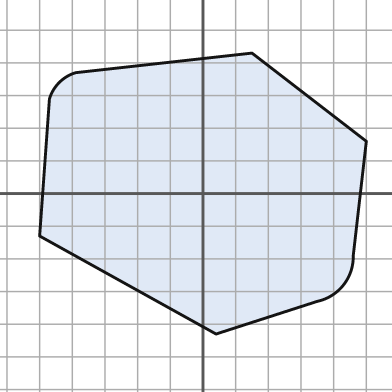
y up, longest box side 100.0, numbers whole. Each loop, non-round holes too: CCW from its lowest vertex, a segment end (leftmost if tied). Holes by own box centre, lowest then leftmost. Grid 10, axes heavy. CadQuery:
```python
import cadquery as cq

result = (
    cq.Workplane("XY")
    .moveTo(4.0, -43.0)
    .lineTo(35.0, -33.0)
    .threePointArc((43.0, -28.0), (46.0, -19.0))
    .lineTo(50.0, 16.0)
    .lineTo(15.0, 43.0)
    .lineTo(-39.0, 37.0)
    .threePointArc((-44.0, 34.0), (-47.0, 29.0))
    .lineTo(-50.0, -13.0)
    .close()
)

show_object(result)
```